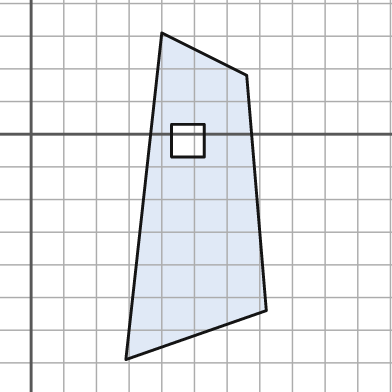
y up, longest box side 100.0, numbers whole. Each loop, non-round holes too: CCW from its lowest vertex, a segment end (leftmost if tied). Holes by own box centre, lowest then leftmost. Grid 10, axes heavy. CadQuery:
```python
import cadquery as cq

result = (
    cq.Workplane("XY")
    .moveTo(29.0, -69.0)
    .lineTo(72.0, -54.0)
    .lineTo(66.0, 18.0)
    .lineTo(40.0, 31.0)
    .close()
    .moveTo(43.0, -7.0)
    .lineTo(53.0, -7.0)
    .lineTo(53.0, 3.0)
    .lineTo(43.0, 3.0)
    .close()
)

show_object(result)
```